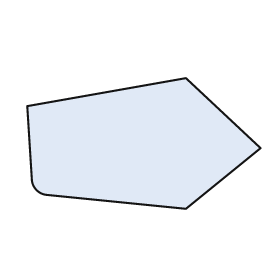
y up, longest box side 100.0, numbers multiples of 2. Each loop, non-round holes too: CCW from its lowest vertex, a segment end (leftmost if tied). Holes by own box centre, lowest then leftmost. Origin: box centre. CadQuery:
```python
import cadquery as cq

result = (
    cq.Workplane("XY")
    .moveTo(18.0, -28.0)
    .lineTo(50.0, -2.0)
    .lineTo(18.0, 28.0)
    .lineTo(-50.0, 16.0)
    .lineTo(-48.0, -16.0)
    .threePointArc((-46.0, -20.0), (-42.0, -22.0))
    .close()
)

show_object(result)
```